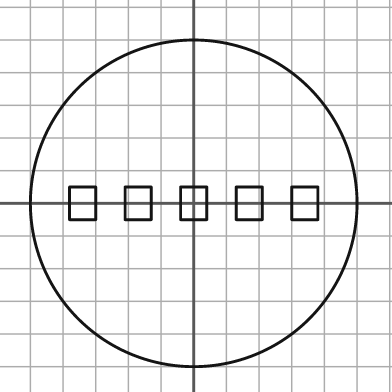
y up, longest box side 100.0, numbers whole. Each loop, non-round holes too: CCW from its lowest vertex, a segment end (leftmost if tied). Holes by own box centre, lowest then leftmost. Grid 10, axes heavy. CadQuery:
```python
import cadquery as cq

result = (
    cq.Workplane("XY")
    .moveTo(0.0, 0.0)
    .circle(50.0)
    .moveTo(-38.0, -5.0)
    .lineTo(-30.0, -5.0)
    .lineTo(-30.0, 5.0)
    .lineTo(-38.0, 5.0)
    .close()
    .moveTo(-21.0, -5.0)
    .lineTo(-13.0, -5.0)
    .lineTo(-13.0, 5.0)
    .lineTo(-21.0, 5.0)
    .close()
    .moveTo(-4.0, -5.0)
    .lineTo(4.0, -5.0)
    .lineTo(4.0, 5.0)
    .lineTo(-4.0, 5.0)
    .close()
    .moveTo(13.0, -5.0)
    .lineTo(21.0, -5.0)
    .lineTo(21.0, 5.0)
    .lineTo(13.0, 5.0)
    .close()
    .moveTo(30.0, -5.0)
    .lineTo(38.0, -5.0)
    .lineTo(38.0, 5.0)
    .lineTo(30.0, 5.0)
    .close()
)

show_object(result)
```